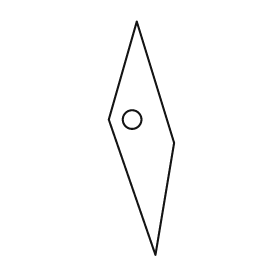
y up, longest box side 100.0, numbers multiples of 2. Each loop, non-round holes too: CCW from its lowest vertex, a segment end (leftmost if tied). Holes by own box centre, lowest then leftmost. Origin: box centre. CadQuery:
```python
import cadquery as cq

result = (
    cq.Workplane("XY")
    .moveTo(6.0, -50.0)
    .lineTo(14.0, -2.0)
    .lineTo(-2.0, 50.0)
    .lineTo(-14.0, 8.0)
    .close()
    .moveTo(-4.0, 8.0)
    .circle(4.0)
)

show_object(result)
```